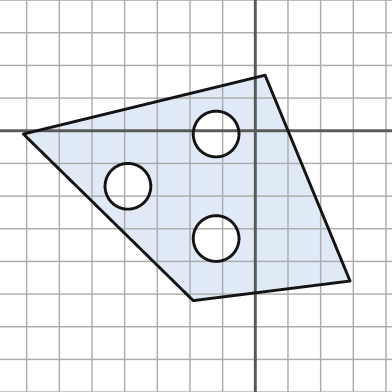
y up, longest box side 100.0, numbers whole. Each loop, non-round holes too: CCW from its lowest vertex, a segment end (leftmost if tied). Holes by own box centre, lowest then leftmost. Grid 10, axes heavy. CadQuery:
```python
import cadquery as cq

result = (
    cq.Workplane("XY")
    .moveTo(-19.0, -52.0)
    .lineTo(29.0, -46.0)
    .lineTo(3.0, 17.0)
    .lineTo(-71.0, -1.0)
    .close()
    .moveTo(-12.0, -33.0)
    .circle(7.0)
    .moveTo(-39.0, -17.0)
    .circle(7.0)
    .moveTo(-12.0, -1.0)
    .circle(7.0)
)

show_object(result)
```